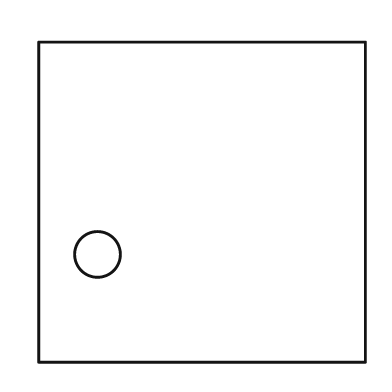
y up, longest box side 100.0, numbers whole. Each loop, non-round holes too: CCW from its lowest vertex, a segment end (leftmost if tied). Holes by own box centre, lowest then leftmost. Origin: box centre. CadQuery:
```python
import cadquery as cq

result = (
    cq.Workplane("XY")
    .moveTo(-50.0, -49.0)
    .lineTo(50.0, -49.0)
    .lineTo(50.0, 49.0)
    .lineTo(-50.0, 49.0)
    .close()
    .moveTo(-32.0, -16.0)
    .circle(7.0)
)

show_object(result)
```